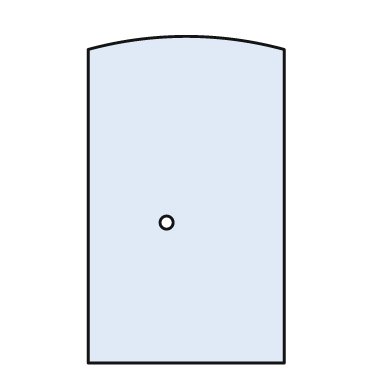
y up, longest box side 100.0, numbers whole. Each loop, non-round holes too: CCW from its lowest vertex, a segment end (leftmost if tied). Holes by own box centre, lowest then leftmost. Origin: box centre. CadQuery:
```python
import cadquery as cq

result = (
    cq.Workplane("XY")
    .moveTo(-30.0, -50.0)
    .lineTo(30.0, -50.0)
    .lineTo(30.0, 46.0)
    .threePointArc((0.0, 50.0), (-30.0, 46.0))
    .close()
    .moveTo(-6.0, -7.0)
    .circle(2.0)
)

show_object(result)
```